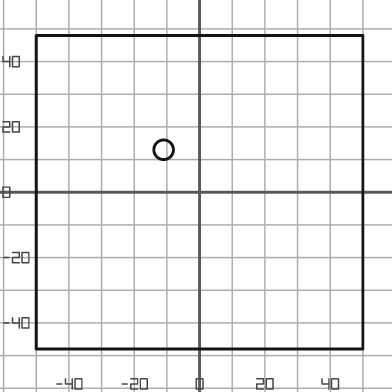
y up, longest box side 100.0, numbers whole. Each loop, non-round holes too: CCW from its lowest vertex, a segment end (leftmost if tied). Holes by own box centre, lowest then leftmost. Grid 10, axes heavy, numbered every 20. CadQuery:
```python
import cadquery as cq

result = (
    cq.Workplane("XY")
    .moveTo(-50.0, -48.0)
    .lineTo(50.0, -48.0)
    .lineTo(50.0, 48.0)
    .lineTo(-50.0, 48.0)
    .close()
    .moveTo(-11.0, 13.0)
    .circle(3.0)
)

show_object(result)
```